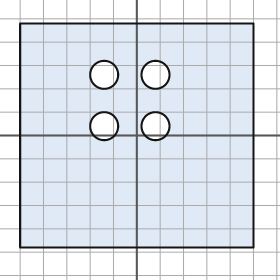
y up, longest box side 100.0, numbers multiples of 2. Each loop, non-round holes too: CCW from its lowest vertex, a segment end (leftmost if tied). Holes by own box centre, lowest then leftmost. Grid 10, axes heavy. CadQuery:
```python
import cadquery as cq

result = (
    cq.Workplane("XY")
    .moveTo(-50.0, -48.0)
    .lineTo(50.0, -48.0)
    .lineTo(50.0, 48.0)
    .lineTo(-50.0, 48.0)
    .close()
    .moveTo(-14.0, 4.0)
    .circle(6.0)
    .moveTo(8.0, 4.0)
    .circle(6.0)
    .moveTo(-14.0, 26.0)
    .circle(6.0)
    .moveTo(8.0, 26.0)
    .circle(6.0)
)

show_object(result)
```